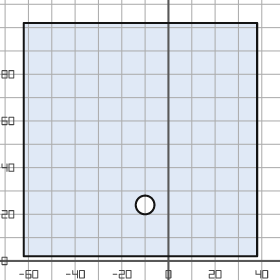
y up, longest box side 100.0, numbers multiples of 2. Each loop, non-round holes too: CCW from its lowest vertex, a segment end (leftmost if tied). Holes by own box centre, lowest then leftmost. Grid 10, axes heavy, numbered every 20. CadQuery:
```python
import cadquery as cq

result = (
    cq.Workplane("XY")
    .moveTo(-62.0, 2.0)
    .lineTo(38.0, 2.0)
    .lineTo(38.0, 102.0)
    .lineTo(-62.0, 102.0)
    .close()
    .moveTo(-10.0, 24.0)
    .circle(4.0)
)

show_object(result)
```